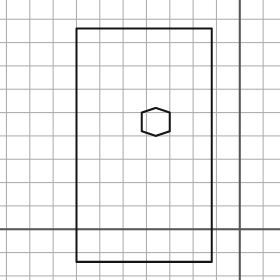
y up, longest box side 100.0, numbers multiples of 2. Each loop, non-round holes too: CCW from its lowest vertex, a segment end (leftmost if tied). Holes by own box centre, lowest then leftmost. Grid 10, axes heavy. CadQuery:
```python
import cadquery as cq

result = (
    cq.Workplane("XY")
    .moveTo(-70.0, -14.0)
    .lineTo(-12.0, -14.0)
    .lineTo(-12.0, 86.0)
    .lineTo(-70.0, 86.0)
    .close()
    .moveTo(-36.0, 40.0)
    .lineTo(-30.0, 42.0)
    .lineTo(-30.0, 50.0)
    .lineTo(-36.0, 52.0)
    .lineTo(-42.0, 50.0)
    .lineTo(-42.0, 42.0)
    .close()
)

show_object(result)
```